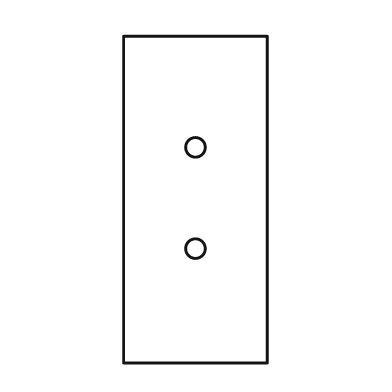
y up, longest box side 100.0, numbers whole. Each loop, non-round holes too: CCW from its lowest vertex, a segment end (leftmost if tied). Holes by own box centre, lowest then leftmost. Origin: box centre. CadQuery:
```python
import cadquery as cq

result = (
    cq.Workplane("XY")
    .moveTo(-22.0, -50.0)
    .lineTo(22.0, -50.0)
    .lineTo(22.0, 50.0)
    .lineTo(-22.0, 50.0)
    .close()
    .moveTo(0.0, -15.0)
    .circle(3.0)
    .moveTo(0.0, 16.0)
    .circle(3.0)
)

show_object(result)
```